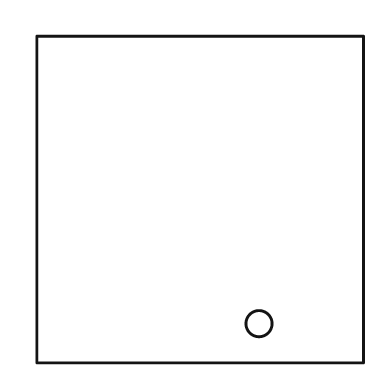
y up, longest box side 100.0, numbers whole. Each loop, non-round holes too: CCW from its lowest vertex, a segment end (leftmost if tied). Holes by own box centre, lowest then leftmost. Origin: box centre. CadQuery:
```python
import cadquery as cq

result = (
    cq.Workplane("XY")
    .moveTo(-50.0, -50.0)
    .lineTo(50.0, -50.0)
    .lineTo(50.0, 50.0)
    .lineTo(-50.0, 50.0)
    .close()
    .moveTo(18.0, -38.0)
    .circle(4.0)
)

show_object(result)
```